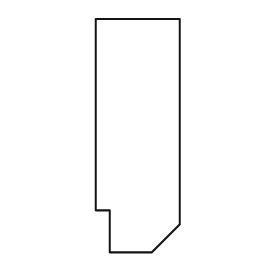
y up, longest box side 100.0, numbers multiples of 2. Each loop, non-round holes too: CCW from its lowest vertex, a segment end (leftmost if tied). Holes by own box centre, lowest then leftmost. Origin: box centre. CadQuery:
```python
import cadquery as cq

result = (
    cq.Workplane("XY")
    .moveTo(-12.0, -50.0)
    .lineTo(6.0, -50.0)
    .lineTo(18.0, -38.0)
    .lineTo(18.0, 50.0)
    .lineTo(-18.0, 50.0)
    .lineTo(-18.0, -32.0)
    .lineTo(-12.0, -32.0)
    .close()
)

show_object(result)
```